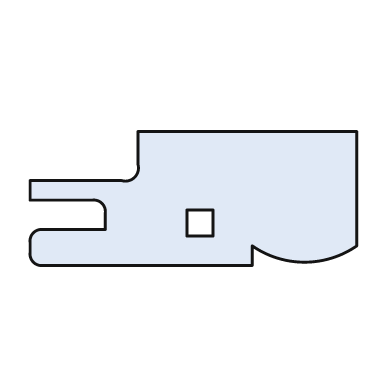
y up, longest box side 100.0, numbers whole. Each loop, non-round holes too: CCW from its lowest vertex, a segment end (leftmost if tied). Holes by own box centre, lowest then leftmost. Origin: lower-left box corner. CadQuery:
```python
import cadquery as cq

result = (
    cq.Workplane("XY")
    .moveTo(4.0, 0.0)
    .lineTo(68.0, 0.0)
    .lineTo(68.0, 6.0)
    .threePointArc((84.0, 1.0), (100.0, 6.0))
    .lineTo(100.0, 41.0)
    .lineTo(33.0, 41.0)
    .lineTo(33.0, 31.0)
    .threePointArc((32.0, 27.0), (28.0, 26.0))
    .lineTo(0.0, 26.0)
    .lineTo(0.0, 20.0)
    .lineTo(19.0, 20.0)
    .threePointArc((22.0, 19.0), (23.0, 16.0))
    .lineTo(23.0, 11.0)
    .lineTo(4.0, 11.0)
    .threePointArc((1.0, 10.0), (0.0, 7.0))
    .lineTo(0.0, 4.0)
    .threePointArc((1.0, 1.0), (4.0, 0.0))
    .close()
    .moveTo(48.0, 9.0)
    .lineTo(56.0, 9.0)
    .lineTo(56.0, 17.0)
    .lineTo(48.0, 17.0)
    .close()
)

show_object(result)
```